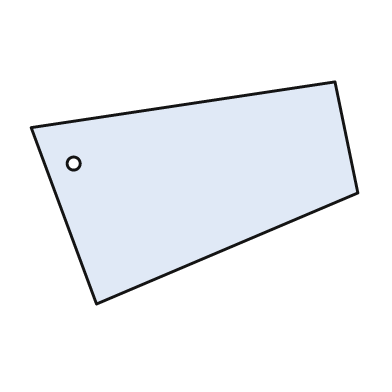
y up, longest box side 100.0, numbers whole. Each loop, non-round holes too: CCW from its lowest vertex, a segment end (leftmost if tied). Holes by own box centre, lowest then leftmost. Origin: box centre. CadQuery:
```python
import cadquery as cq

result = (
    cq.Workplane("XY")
    .moveTo(-30.0, -34.0)
    .lineTo(50.0, 0.0)
    .lineTo(43.0, 34.0)
    .lineTo(-50.0, 20.0)
    .close()
    .moveTo(-37.0, 9.0)
    .circle(2.0)
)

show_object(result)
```